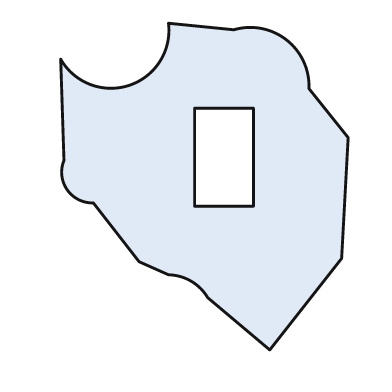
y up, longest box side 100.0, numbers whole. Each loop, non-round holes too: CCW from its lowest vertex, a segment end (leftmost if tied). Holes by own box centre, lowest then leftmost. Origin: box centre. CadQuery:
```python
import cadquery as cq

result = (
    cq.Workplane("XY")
    .moveTo(20.0, -50.0)
    .lineTo(42.0, -22.0)
    .lineTo(44.0, 15.0)
    .lineTo(32.0, 30.0)
    .threePointArc((25.0, 45.0), (9.0, 48.0))
    .lineTo(-11.0, 50.0)
    .threePointArc((-23.0, 31.0), (-44.0, 39.0))
    .lineTo(-43.0, 8.0)
    .threePointArc((-42.0, -1.0), (-34.0, -5.0))
    .lineTo(-20.0, -23.0)
    .lineTo(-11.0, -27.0)
    .threePointArc((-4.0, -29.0), (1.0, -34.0))
    .close()
    .moveTo(-3.0, -6.0)
    .lineTo(15.0, -6.0)
    .lineTo(15.0, 24.0)
    .lineTo(-3.0, 24.0)
    .close()
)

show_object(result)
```